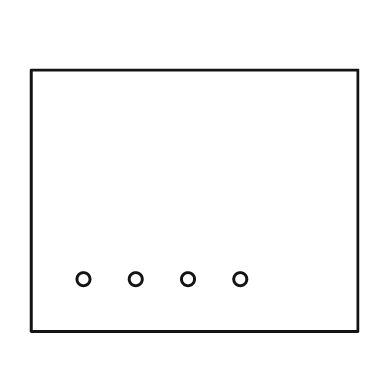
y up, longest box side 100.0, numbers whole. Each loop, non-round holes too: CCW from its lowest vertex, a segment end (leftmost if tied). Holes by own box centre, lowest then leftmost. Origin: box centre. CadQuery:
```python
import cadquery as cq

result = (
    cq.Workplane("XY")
    .moveTo(-50.0, -40.0)
    .lineTo(50.0, -40.0)
    .lineTo(50.0, 40.0)
    .lineTo(-50.0, 40.0)
    .close()
    .moveTo(-34.0, -24.0)
    .circle(2.0)
    .moveTo(-18.0, -24.0)
    .circle(2.0)
    .moveTo(-2.0, -24.0)
    .circle(2.0)
    .moveTo(14.0, -24.0)
    .circle(2.0)
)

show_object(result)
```